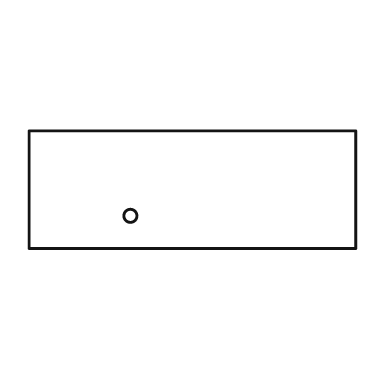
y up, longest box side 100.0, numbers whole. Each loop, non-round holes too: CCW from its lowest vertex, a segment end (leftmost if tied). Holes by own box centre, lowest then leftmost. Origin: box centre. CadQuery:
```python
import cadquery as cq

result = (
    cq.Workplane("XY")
    .moveTo(-50.0, -18.0)
    .lineTo(50.0, -18.0)
    .lineTo(50.0, 18.0)
    .lineTo(-50.0, 18.0)
    .close()
    .moveTo(-19.0, -8.0)
    .circle(2.0)
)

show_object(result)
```